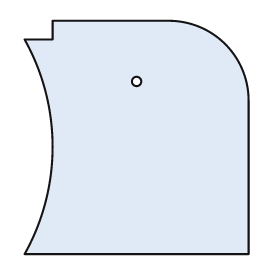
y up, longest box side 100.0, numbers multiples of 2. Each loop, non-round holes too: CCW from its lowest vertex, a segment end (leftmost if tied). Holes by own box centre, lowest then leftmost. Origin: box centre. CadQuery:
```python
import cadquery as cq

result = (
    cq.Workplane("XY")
    .moveTo(-48.0, -50.0)
    .lineTo(48.0, -50.0)
    .lineTo(48.0, 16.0)
    .threePointArc((38.0, 40.0), (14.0, 50.0))
    .lineTo(-36.0, 50.0)
    .lineTo(-36.0, 42.0)
    .lineTo(-48.0, 42.0)
    .threePointArc((-36.0, -4.0), (-48.0, -50.0))
    .close()
    .moveTo(0.0, 24.0)
    .circle(2.0)
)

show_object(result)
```